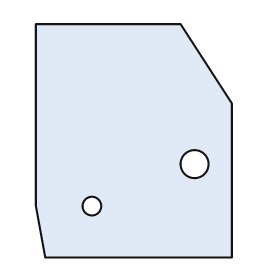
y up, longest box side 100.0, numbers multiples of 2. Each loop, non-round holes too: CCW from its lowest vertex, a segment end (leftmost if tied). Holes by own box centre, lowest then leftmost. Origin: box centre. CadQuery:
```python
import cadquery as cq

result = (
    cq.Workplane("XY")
    .moveTo(-38.0, -50.0)
    .lineTo(42.0, -50.0)
    .lineTo(42.0, 16.0)
    .lineTo(20.0, 50.0)
    .lineTo(-42.0, 50.0)
    .lineTo(-42.0, -28.0)
    .close()
    .moveTo(-18.0, -28.0)
    .circle(4.0)
    .moveTo(26.0, -10.0)
    .circle(6.0)
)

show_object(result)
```